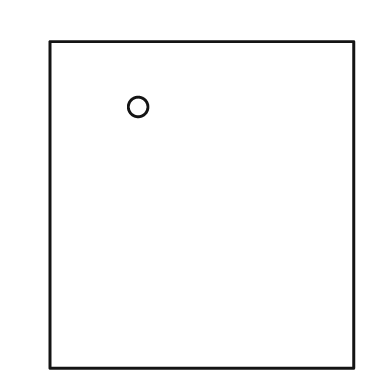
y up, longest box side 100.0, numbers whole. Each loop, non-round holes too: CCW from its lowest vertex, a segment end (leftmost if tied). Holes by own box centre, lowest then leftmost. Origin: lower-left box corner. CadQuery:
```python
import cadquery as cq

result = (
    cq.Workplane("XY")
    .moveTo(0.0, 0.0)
    .lineTo(93.0, 0.0)
    .lineTo(93.0, 100.0)
    .lineTo(0.0, 100.0)
    .close()
    .moveTo(27.0, 80.0)
    .circle(3.0)
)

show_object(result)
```